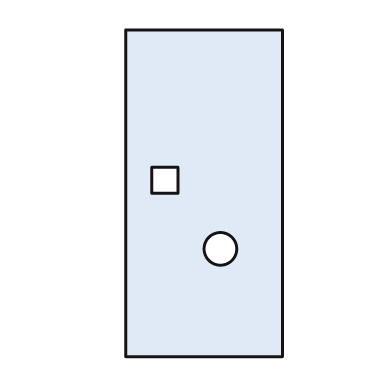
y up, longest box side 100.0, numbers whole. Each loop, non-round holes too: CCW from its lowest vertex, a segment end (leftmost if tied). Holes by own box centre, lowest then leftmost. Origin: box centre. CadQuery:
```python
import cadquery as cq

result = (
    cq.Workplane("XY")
    .moveTo(-24.0, -50.0)
    .lineTo(24.0, -50.0)
    .lineTo(24.0, 50.0)
    .lineTo(-24.0, 50.0)
    .close()
    .moveTo(5.0, -17.0)
    .circle(5.0)
    .moveTo(-16.0, 0.0)
    .lineTo(-8.0, 0.0)
    .lineTo(-8.0, 8.0)
    .lineTo(-16.0, 8.0)
    .close()
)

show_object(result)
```